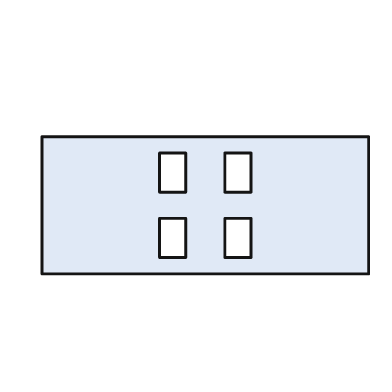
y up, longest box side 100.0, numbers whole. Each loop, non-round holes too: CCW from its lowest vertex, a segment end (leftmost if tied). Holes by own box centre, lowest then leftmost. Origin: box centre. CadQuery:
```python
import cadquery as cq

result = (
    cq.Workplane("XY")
    .moveTo(-50.0, -21.0)
    .lineTo(50.0, -21.0)
    .lineTo(50.0, 21.0)
    .lineTo(-50.0, 21.0)
    .close()
    .moveTo(-14.0, -16.0)
    .lineTo(-6.0, -16.0)
    .lineTo(-6.0, -4.0)
    .lineTo(-14.0, -4.0)
    .close()
    .moveTo(6.0, -16.0)
    .lineTo(14.0, -16.0)
    .lineTo(14.0, -4.0)
    .lineTo(6.0, -4.0)
    .close()
    .moveTo(-14.0, 4.0)
    .lineTo(-6.0, 4.0)
    .lineTo(-6.0, 16.0)
    .lineTo(-14.0, 16.0)
    .close()
    .moveTo(6.0, 4.0)
    .lineTo(14.0, 4.0)
    .lineTo(14.0, 16.0)
    .lineTo(6.0, 16.0)
    .close()
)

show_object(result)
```